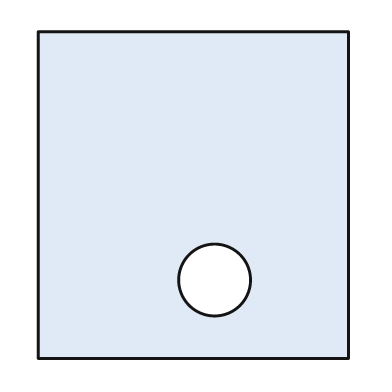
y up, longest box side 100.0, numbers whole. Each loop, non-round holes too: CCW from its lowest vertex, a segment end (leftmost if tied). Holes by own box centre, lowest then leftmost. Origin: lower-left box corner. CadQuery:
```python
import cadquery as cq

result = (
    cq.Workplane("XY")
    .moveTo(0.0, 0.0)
    .lineTo(95.0, 0.0)
    .lineTo(95.0, 100.0)
    .lineTo(0.0, 100.0)
    .close()
    .moveTo(54.0, 24.0)
    .circle(11.0)
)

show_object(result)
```